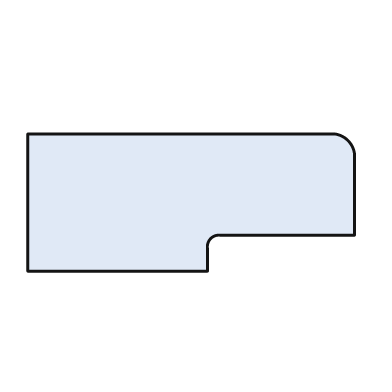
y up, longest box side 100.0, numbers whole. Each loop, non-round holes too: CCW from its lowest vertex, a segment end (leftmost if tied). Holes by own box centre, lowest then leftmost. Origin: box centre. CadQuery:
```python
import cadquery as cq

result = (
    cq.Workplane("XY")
    .moveTo(-50.0, -21.0)
    .lineTo(5.0, -21.0)
    .lineTo(5.0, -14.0)
    .threePointArc((6.0, -11.0), (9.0, -10.0))
    .lineTo(50.0, -10.0)
    .lineTo(50.0, 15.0)
    .threePointArc((48.0, 19.0), (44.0, 21.0))
    .lineTo(-50.0, 21.0)
    .close()
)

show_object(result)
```